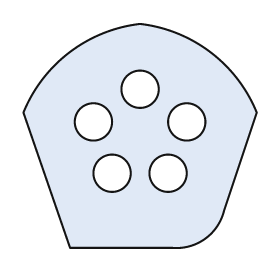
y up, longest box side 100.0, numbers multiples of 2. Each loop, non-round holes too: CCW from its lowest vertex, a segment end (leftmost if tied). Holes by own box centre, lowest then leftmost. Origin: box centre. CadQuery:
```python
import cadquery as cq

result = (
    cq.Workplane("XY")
    .moveTo(-30.0, -48.0)
    .lineTo(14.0, -48.0)
    .threePointArc((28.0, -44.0), (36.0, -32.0))
    .lineTo(50.0, 10.0)
    .threePointArc((30.0, 36.0), (0.0, 48.0))
    .threePointArc((-30.0, 36.0), (-50.0, 10.0))
    .close()
    .moveTo(-12.0, -16.0)
    .circle(8.0)
    .moveTo(12.0, -16.0)
    .circle(8.0)
    .moveTo(-20.0, 6.0)
    .circle(8.0)
    .moveTo(20.0, 6.0)
    .circle(8.0)
    .moveTo(0.0, 20.0)
    .circle(8.0)
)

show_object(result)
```